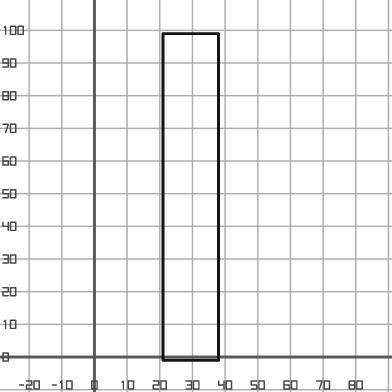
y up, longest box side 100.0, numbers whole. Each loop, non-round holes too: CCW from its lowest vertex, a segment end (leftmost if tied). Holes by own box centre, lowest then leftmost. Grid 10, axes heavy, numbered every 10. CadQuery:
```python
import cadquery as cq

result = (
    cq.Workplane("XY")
    .moveTo(21.0, -1.0)
    .lineTo(38.0, -1.0)
    .lineTo(38.0, 99.0)
    .lineTo(21.0, 99.0)
    .close()
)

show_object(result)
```